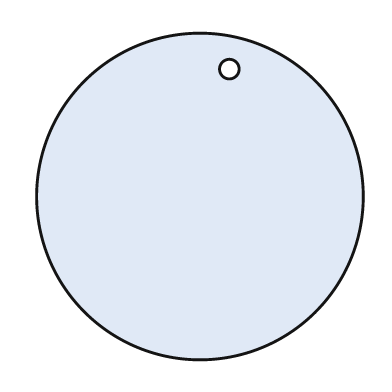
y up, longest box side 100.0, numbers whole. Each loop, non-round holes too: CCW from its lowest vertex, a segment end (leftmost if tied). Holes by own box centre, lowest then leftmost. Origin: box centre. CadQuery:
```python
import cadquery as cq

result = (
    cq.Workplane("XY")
    .moveTo(0.0, 0.0)
    .circle(50.0)
    .moveTo(9.0, 39.0)
    .circle(3.0)
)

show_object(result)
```